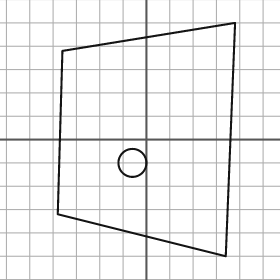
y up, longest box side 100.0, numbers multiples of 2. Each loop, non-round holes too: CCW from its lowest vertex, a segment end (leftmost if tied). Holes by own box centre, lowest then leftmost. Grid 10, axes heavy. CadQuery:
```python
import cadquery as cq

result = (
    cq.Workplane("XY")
    .moveTo(34.0, -50.0)
    .lineTo(38.0, 50.0)
    .lineTo(-36.0, 38.0)
    .lineTo(-38.0, -32.0)
    .close()
    .moveTo(-6.0, -10.0)
    .circle(6.0)
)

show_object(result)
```